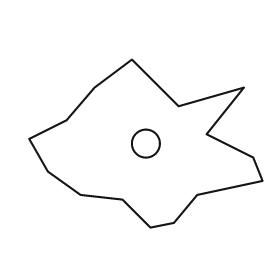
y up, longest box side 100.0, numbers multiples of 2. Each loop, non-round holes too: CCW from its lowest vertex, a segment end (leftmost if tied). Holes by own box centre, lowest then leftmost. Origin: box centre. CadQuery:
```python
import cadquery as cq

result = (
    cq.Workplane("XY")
    .moveTo(2.0, -36.0)
    .lineTo(12.0, -34.0)
    .lineTo(22.0, -22.0)
    .lineTo(50.0, -16.0)
    .lineTo(46.0, -6.0)
    .lineTo(26.0, 4.0)
    .lineTo(42.0, 24.0)
    .lineTo(14.0, 16.0)
    .lineTo(-6.0, 36.0)
    .lineTo(-22.0, 24.0)
    .lineTo(-34.0, 10.0)
    .lineTo(-50.0, 2.0)
    .lineTo(-42.0, -12.0)
    .lineTo(-28.0, -22.0)
    .lineTo(-10.0, -24.0)
    .close()
    .moveTo(0.0, 0.0)
    .circle(6.0)
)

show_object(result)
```